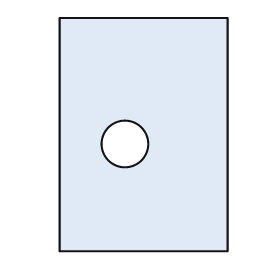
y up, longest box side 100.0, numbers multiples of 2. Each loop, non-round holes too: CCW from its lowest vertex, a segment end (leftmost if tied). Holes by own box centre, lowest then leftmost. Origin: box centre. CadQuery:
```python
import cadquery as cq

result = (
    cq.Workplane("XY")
    .moveTo(-36.0, -50.0)
    .lineTo(36.0, -50.0)
    .lineTo(36.0, 50.0)
    .lineTo(-36.0, 50.0)
    .close()
    .moveTo(-8.0, -4.0)
    .circle(10.0)
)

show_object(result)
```